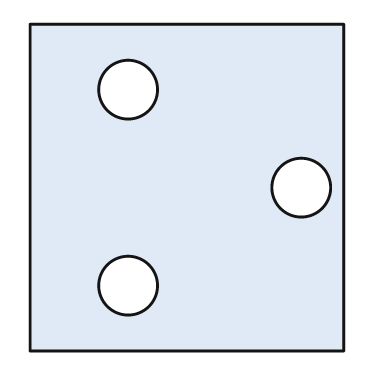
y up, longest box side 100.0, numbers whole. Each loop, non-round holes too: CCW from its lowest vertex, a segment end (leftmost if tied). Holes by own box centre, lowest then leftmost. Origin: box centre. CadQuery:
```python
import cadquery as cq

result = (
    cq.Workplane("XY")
    .moveTo(-48.0, -50.0)
    .lineTo(48.0, -50.0)
    .lineTo(48.0, 50.0)
    .lineTo(-48.0, 50.0)
    .close()
    .moveTo(-18.0, -30.0)
    .circle(9.0)
    .moveTo(35.0, 0.0)
    .circle(9.0)
    .moveTo(-18.0, 30.0)
    .circle(9.0)
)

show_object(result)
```